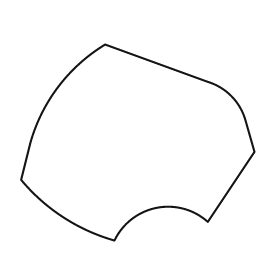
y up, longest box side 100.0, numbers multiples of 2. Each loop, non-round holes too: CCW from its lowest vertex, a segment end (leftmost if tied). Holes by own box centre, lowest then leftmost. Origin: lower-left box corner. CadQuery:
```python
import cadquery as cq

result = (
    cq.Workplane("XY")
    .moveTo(40.0, 0.0)
    .threePointArc((58.0, 14.0), (80.0, 8.0))
    .lineTo(100.0, 38.0)
    .lineTo(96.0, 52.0)
    .threePointArc((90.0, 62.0), (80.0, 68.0))
    .lineTo(36.0, 84.0)
    .threePointArc((16.0, 66.0), (4.0, 42.0))
    .lineTo(0.0, 26.0)
    .threePointArc((18.0, 10.0), (40.0, 0.0))
    .close()
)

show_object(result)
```